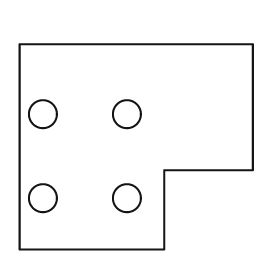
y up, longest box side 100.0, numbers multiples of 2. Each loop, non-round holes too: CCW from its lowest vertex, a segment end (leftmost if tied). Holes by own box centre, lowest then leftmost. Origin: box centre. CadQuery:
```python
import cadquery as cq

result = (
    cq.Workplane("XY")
    .moveTo(-50.0, -44.0)
    .lineTo(12.0, -44.0)
    .lineTo(12.0, -10.0)
    .lineTo(50.0, -10.0)
    .lineTo(50.0, 44.0)
    .lineTo(-50.0, 44.0)
    .close()
    .moveTo(-40.0, -22.0)
    .circle(6.0)
    .moveTo(-4.0, -22.0)
    .circle(6.0)
    .moveTo(-40.0, 14.0)
    .circle(6.0)
    .moveTo(-4.0, 14.0)
    .circle(6.0)
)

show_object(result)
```